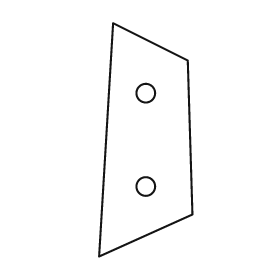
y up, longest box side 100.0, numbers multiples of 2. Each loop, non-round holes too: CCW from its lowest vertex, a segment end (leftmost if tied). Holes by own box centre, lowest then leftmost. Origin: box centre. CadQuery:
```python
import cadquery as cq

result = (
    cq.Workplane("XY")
    .moveTo(-20.0, -50.0)
    .lineTo(20.0, -32.0)
    .lineTo(18.0, 34.0)
    .lineTo(-14.0, 50.0)
    .close()
    .moveTo(0.0, -20.0)
    .circle(4.0)
    .moveTo(0.0, 20.0)
    .circle(4.0)
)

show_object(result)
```